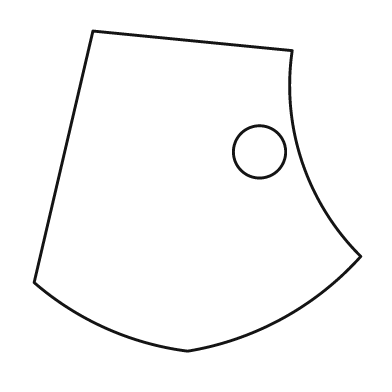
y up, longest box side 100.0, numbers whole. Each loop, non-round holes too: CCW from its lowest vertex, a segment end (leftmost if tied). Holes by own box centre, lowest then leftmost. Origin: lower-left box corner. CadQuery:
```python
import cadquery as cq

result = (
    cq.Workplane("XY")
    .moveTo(47.0, 0.0)
    .threePointArc((76.0, 10.0), (100.0, 29.0))
    .threePointArc((82.0, 58.0), (79.0, 92.0))
    .lineTo(18.0, 98.0)
    .lineTo(0.0, 21.0)
    .threePointArc((22.0, 7.0), (47.0, 0.0))
    .close()
    .moveTo(69.0, 61.0)
    .circle(8.0)
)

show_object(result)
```